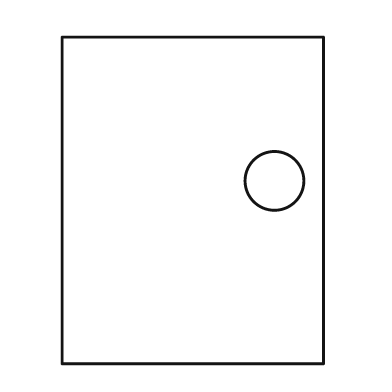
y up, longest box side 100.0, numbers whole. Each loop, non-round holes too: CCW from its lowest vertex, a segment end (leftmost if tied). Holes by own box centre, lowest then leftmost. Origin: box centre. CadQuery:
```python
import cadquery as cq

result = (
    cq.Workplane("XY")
    .moveTo(-40.0, -50.0)
    .lineTo(40.0, -50.0)
    .lineTo(40.0, 50.0)
    .lineTo(-40.0, 50.0)
    .close()
    .moveTo(25.0, 6.0)
    .circle(9.0)
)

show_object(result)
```